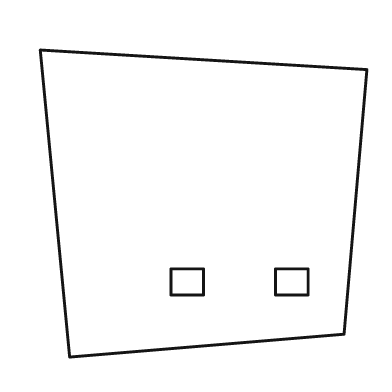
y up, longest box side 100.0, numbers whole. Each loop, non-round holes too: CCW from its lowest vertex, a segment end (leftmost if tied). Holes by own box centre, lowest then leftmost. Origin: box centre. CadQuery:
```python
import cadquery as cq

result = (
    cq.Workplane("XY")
    .moveTo(-41.0, -47.0)
    .lineTo(43.0, -40.0)
    .lineTo(50.0, 41.0)
    .lineTo(-50.0, 47.0)
    .close()
    .moveTo(-10.0, -28.0)
    .lineTo(0.0, -28.0)
    .lineTo(0.0, -20.0)
    .lineTo(-10.0, -20.0)
    .close()
    .moveTo(22.0, -28.0)
    .lineTo(32.0, -28.0)
    .lineTo(32.0, -20.0)
    .lineTo(22.0, -20.0)
    .close()
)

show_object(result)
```